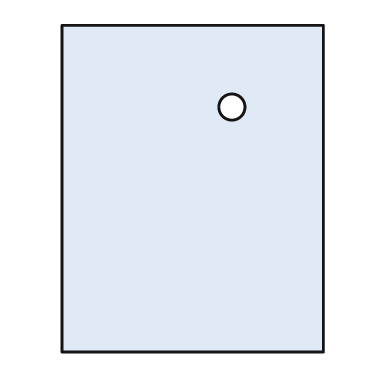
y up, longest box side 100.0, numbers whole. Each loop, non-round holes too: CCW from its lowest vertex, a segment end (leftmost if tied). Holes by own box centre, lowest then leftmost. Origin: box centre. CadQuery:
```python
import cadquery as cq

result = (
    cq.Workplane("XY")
    .moveTo(-40.0, -50.0)
    .lineTo(40.0, -50.0)
    .lineTo(40.0, 50.0)
    .lineTo(-40.0, 50.0)
    .close()
    .moveTo(12.0, 25.0)
    .circle(4.0)
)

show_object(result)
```